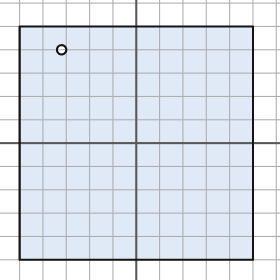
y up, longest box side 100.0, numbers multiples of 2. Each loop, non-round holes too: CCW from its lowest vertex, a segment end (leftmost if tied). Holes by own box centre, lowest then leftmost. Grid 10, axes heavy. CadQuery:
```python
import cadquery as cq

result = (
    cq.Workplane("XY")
    .moveTo(-50.0, -50.0)
    .lineTo(50.0, -50.0)
    .lineTo(50.0, 50.0)
    .lineTo(-50.0, 50.0)
    .close()
    .moveTo(-32.0, 40.0)
    .circle(2.0)
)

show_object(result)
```